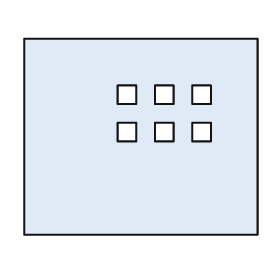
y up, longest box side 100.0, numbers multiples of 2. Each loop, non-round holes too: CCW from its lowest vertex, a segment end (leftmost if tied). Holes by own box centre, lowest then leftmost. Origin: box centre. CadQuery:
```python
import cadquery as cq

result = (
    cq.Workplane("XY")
    .moveTo(-50.0, -42.0)
    .lineTo(50.0, -42.0)
    .lineTo(50.0, 42.0)
    .lineTo(-50.0, 42.0)
    .close()
    .moveTo(-10.0, -2.0)
    .lineTo(-2.0, -2.0)
    .lineTo(-2.0, 6.0)
    .lineTo(-10.0, 6.0)
    .close()
    .moveTo(6.0, -2.0)
    .lineTo(14.0, -2.0)
    .lineTo(14.0, 6.0)
    .lineTo(6.0, 6.0)
    .close()
    .moveTo(22.0, -2.0)
    .lineTo(30.0, -2.0)
    .lineTo(30.0, 6.0)
    .lineTo(22.0, 6.0)
    .close()
    .moveTo(-10.0, 14.0)
    .lineTo(-2.0, 14.0)
    .lineTo(-2.0, 22.0)
    .lineTo(-10.0, 22.0)
    .close()
    .moveTo(6.0, 14.0)
    .lineTo(14.0, 14.0)
    .lineTo(14.0, 22.0)
    .lineTo(6.0, 22.0)
    .close()
    .moveTo(22.0, 14.0)
    .lineTo(30.0, 14.0)
    .lineTo(30.0, 22.0)
    .lineTo(22.0, 22.0)
    .close()
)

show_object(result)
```